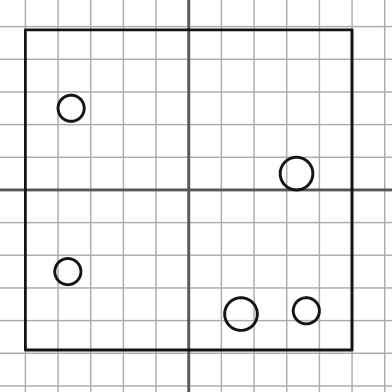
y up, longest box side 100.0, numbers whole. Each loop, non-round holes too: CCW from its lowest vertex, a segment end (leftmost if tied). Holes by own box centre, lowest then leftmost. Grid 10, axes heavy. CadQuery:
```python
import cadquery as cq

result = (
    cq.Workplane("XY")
    .moveTo(-50.0, -49.0)
    .lineTo(50.0, -49.0)
    .lineTo(50.0, 49.0)
    .lineTo(-50.0, 49.0)
    .close()
    .moveTo(16.0, -38.0)
    .circle(5.0)
    .moveTo(36.0, -37.0)
    .circle(4.0)
    .moveTo(-37.0, -25.0)
    .circle(4.0)
    .moveTo(33.0, 5.0)
    .circle(5.0)
    .moveTo(-36.0, 25.0)
    .circle(4.0)
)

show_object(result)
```